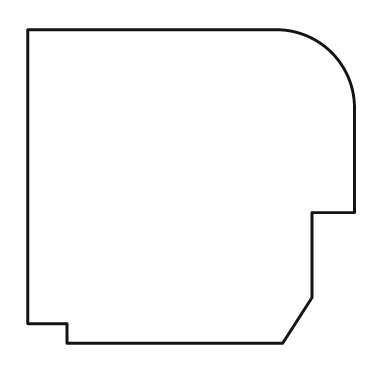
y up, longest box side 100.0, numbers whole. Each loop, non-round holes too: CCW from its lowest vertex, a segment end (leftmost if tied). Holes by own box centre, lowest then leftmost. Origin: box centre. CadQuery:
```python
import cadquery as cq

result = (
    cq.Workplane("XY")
    .moveTo(-38.0, -48.0)
    .lineTo(28.0, -48.0)
    .lineTo(37.0, -34.0)
    .lineTo(37.0, -8.0)
    .lineTo(50.0, -8.0)
    .lineTo(50.0, 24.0)
    .threePointArc((43.0, 41.0), (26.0, 48.0))
    .lineTo(-50.0, 48.0)
    .lineTo(-50.0, -42.0)
    .lineTo(-38.0, -42.0)
    .close()
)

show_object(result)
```